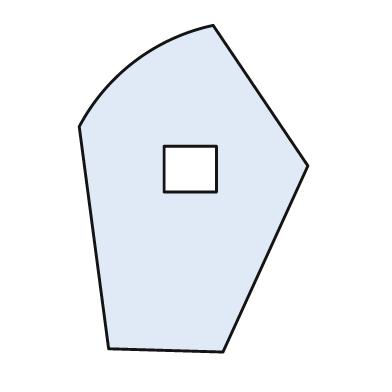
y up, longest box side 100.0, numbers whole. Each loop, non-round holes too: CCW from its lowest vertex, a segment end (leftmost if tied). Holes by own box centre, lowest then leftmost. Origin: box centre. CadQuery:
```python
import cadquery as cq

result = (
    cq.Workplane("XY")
    .moveTo(9.0, -50.0)
    .lineTo(35.0, 7.0)
    .lineTo(6.0, 50.0)
    .threePointArc((-18.0, 39.0), (-35.0, 19.0))
    .lineTo(-26.0, -49.0)
    .close()
    .moveTo(-9.0, -1.0)
    .lineTo(7.0, -1.0)
    .lineTo(7.0, 13.0)
    .lineTo(-9.0, 13.0)
    .close()
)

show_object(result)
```